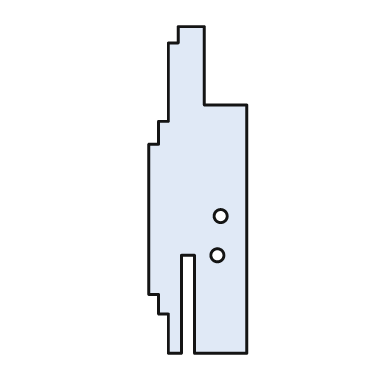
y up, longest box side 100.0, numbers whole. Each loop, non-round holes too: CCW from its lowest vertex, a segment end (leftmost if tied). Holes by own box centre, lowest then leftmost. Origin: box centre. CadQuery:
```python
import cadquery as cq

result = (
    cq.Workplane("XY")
    .moveTo(-9.0, -50.0)
    .lineTo(-5.0, -50.0)
    .lineTo(-5.0, -20.0)
    .lineTo(-1.0, -20.0)
    .lineTo(-1.0, -50.0)
    .lineTo(15.0, -50.0)
    .lineTo(15.0, 26.0)
    .lineTo(2.0, 26.0)
    .lineTo(2.0, 50.0)
    .lineTo(-6.0, 50.0)
    .lineTo(-6.0, 45.0)
    .lineTo(-9.0, 45.0)
    .lineTo(-9.0, 21.0)
    .lineTo(-12.0, 21.0)
    .lineTo(-12.0, 14.0)
    .lineTo(-15.0, 14.0)
    .lineTo(-15.0, -32.0)
    .lineTo(-12.0, -32.0)
    .lineTo(-12.0, -38.0)
    .lineTo(-9.0, -38.0)
    .close()
    .moveTo(6.0, -20.0)
    .circle(2.0)
    .moveTo(7.0, -8.0)
    .circle(2.0)
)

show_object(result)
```